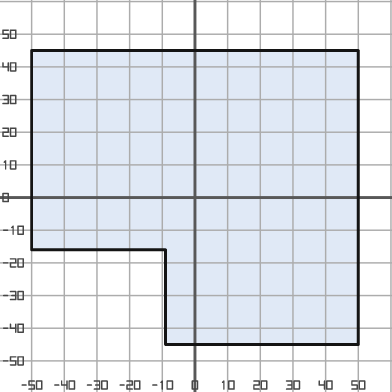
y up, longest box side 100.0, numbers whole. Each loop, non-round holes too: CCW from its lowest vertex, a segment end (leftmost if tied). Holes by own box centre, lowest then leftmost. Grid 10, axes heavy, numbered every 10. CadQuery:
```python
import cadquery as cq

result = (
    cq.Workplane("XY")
    .moveTo(-9.0, -45.0)
    .lineTo(50.0, -45.0)
    .lineTo(50.0, 45.0)
    .lineTo(-50.0, 45.0)
    .lineTo(-50.0, -16.0)
    .lineTo(-9.0, -16.0)
    .close()
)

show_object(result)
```